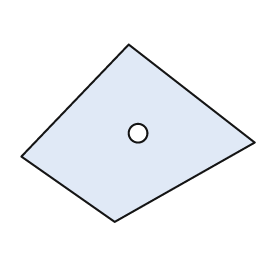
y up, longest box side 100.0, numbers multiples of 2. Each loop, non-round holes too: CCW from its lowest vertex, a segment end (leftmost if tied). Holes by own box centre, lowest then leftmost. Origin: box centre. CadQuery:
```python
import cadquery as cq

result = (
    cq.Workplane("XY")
    .moveTo(-10.0, -38.0)
    .lineTo(50.0, -4.0)
    .lineTo(-4.0, 38.0)
    .lineTo(-50.0, -10.0)
    .close()
    .moveTo(0.0, 0.0)
    .circle(4.0)
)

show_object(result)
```